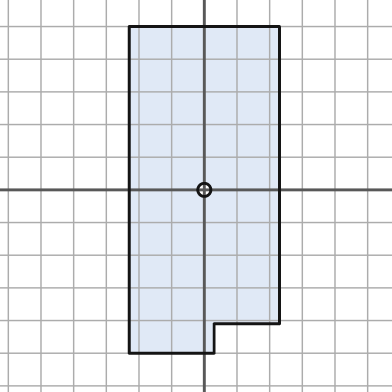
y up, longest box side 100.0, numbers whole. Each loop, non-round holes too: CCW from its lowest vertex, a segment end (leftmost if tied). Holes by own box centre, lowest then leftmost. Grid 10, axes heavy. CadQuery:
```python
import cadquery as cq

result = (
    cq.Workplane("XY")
    .moveTo(-23.0, -50.0)
    .lineTo(3.0, -50.0)
    .lineTo(3.0, -41.0)
    .lineTo(23.0, -41.0)
    .lineTo(23.0, 50.0)
    .lineTo(-23.0, 50.0)
    .close()
    .moveTo(0.0, 0.0)
    .circle(2.0)
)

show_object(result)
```